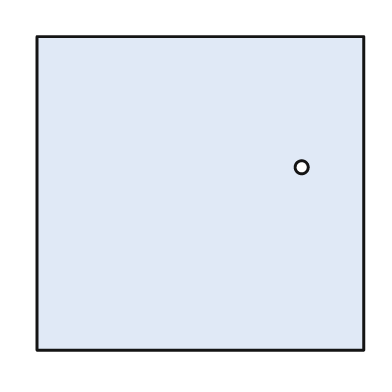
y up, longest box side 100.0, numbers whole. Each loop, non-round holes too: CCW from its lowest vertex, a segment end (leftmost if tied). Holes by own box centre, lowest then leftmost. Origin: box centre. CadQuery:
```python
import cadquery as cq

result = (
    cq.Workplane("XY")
    .moveTo(-50.0, -48.0)
    .lineTo(50.0, -48.0)
    .lineTo(50.0, 48.0)
    .lineTo(-50.0, 48.0)
    .close()
    .moveTo(31.0, 8.0)
    .circle(2.0)
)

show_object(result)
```